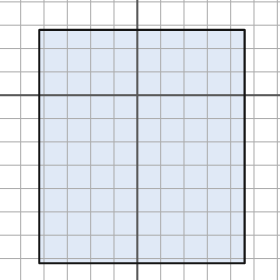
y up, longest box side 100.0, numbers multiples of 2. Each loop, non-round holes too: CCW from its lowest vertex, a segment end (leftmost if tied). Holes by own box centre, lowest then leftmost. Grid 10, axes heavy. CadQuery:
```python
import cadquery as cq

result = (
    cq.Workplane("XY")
    .moveTo(-42.0, -72.0)
    .lineTo(46.0, -72.0)
    .lineTo(46.0, 28.0)
    .lineTo(-42.0, 28.0)
    .close()
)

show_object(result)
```